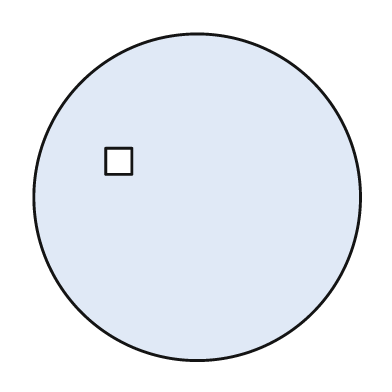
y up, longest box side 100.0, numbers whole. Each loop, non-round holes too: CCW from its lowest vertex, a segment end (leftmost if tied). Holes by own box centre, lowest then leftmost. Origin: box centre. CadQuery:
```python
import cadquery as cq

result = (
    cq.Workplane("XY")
    .moveTo(0.0, 0.0)
    .circle(50.0)
    .moveTo(-28.0, 7.0)
    .lineTo(-20.0, 7.0)
    .lineTo(-20.0, 15.0)
    .lineTo(-28.0, 15.0)
    .close()
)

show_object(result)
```